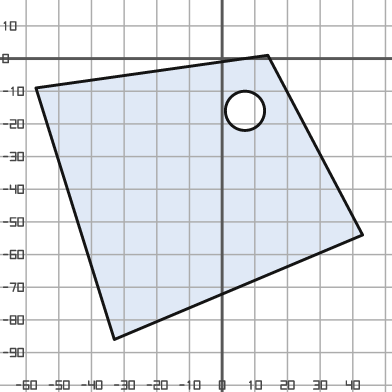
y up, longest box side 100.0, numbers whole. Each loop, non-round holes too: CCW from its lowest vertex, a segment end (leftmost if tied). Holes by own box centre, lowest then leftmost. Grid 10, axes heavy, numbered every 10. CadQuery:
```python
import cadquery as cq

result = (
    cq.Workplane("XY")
    .moveTo(-33.0, -86.0)
    .lineTo(43.0, -54.0)
    .lineTo(14.0, 1.0)
    .lineTo(-57.0, -9.0)
    .close()
    .moveTo(7.0, -16.0)
    .circle(6.0)
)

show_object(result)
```